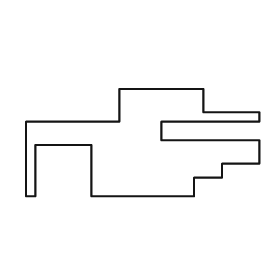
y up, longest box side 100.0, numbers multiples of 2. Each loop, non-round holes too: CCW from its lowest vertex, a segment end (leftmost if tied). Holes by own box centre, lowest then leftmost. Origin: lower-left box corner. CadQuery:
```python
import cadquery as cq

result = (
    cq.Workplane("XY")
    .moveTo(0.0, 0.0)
    .lineTo(4.0, 0.0)
    .lineTo(4.0, 22.0)
    .lineTo(28.0, 22.0)
    .lineTo(28.0, 0.0)
    .lineTo(72.0, 0.0)
    .lineTo(72.0, 8.0)
    .lineTo(84.0, 8.0)
    .lineTo(84.0, 14.0)
    .lineTo(100.0, 14.0)
    .lineTo(100.0, 24.0)
    .lineTo(58.0, 24.0)
    .lineTo(58.0, 32.0)
    .lineTo(100.0, 32.0)
    .lineTo(100.0, 36.0)
    .lineTo(76.0, 36.0)
    .lineTo(76.0, 46.0)
    .lineTo(40.0, 46.0)
    .lineTo(40.0, 32.0)
    .lineTo(0.0, 32.0)
    .close()
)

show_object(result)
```